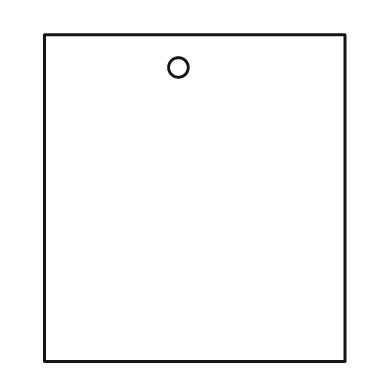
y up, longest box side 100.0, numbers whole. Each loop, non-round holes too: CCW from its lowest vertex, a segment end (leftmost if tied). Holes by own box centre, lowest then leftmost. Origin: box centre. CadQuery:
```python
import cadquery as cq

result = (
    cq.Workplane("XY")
    .moveTo(-46.0, -50.0)
    .lineTo(46.0, -50.0)
    .lineTo(46.0, 50.0)
    .lineTo(-46.0, 50.0)
    .close()
    .moveTo(-5.0, 40.0)
    .circle(3.0)
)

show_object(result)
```